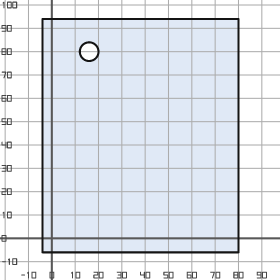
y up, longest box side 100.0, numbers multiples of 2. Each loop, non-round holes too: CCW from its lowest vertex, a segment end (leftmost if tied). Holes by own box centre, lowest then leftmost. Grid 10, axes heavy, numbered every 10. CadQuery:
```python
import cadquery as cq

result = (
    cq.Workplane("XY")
    .moveTo(-4.0, -6.0)
    .lineTo(80.0, -6.0)
    .lineTo(80.0, 94.0)
    .lineTo(-4.0, 94.0)
    .close()
    .moveTo(16.0, 80.0)
    .circle(4.0)
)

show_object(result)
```